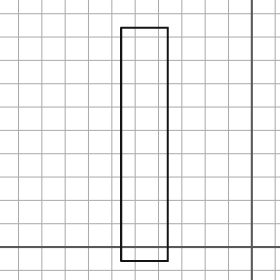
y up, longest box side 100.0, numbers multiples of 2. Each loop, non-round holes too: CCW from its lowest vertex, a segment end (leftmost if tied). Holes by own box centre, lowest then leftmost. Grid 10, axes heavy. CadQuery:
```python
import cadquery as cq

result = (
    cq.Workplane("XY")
    .moveTo(-56.0, -6.0)
    .lineTo(-36.0, -6.0)
    .lineTo(-36.0, 94.0)
    .lineTo(-56.0, 94.0)
    .close()
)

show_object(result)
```